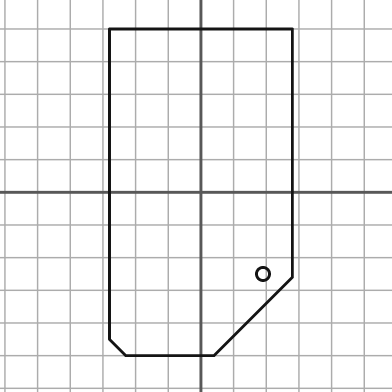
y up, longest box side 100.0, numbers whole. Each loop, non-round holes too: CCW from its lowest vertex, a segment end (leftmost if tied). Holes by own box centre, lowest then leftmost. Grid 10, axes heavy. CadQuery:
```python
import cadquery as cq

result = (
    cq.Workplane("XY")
    .moveTo(-23.0, -50.0)
    .lineTo(4.0, -50.0)
    .lineTo(28.0, -26.0)
    .lineTo(28.0, 50.0)
    .lineTo(-28.0, 50.0)
    .lineTo(-28.0, -45.0)
    .close()
    .moveTo(19.0, -25.0)
    .circle(2.0)
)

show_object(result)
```